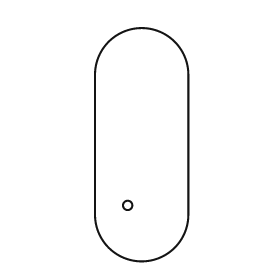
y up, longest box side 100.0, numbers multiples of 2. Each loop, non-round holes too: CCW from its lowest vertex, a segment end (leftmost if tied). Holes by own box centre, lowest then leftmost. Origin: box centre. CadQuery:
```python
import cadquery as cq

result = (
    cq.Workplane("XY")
    .moveTo(-20.0, -30.0)
    .threePointArc((0.0, -50.0), (20.0, -30.0))
    .lineTo(20.0, 30.0)
    .threePointArc((0.0, 50.0), (-20.0, 30.0))
    .close()
    .moveTo(-6.0, -26.0)
    .circle(2.0)
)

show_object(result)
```